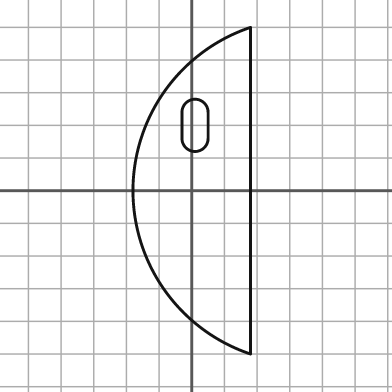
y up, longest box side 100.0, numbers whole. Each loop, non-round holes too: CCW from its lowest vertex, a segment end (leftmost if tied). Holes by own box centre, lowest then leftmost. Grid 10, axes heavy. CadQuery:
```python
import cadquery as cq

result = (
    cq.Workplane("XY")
    .moveTo(18.0, -50.0)
    .lineTo(18.0, 50.0)
    .threePointArc((-18.0, 0.0), (18.0, -50.0))
    .close()
    .moveTo(-3.0, 16.0)
    .threePointArc((1.0, 12.0), (5.0, 16.0))
    .lineTo(5.0, 24.0)
    .threePointArc((1.0, 28.0), (-3.0, 24.0))
    .close()
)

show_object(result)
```